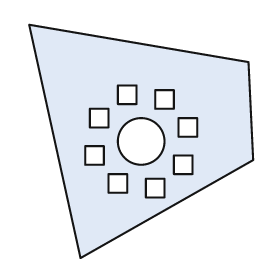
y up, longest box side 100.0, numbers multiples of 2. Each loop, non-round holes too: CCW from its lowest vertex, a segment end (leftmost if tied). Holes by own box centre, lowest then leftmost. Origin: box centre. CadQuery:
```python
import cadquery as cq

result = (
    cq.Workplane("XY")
    .moveTo(-26.0, -50.0)
    .lineTo(48.0, -8.0)
    .lineTo(46.0, 34.0)
    .lineTo(-48.0, 50.0)
    .close()
    .moveTo(2.0, -24.0)
    .lineTo(10.0, -24.0)
    .lineTo(10.0, -16.0)
    .lineTo(2.0, -16.0)
    .close()
    .moveTo(-14.0, -22.0)
    .lineTo(-6.0, -22.0)
    .lineTo(-6.0, -14.0)
    .lineTo(-14.0, -14.0)
    .close()
    .moveTo(14.0, -14.0)
    .lineTo(22.0, -14.0)
    .lineTo(22.0, -6.0)
    .lineTo(14.0, -6.0)
    .close()
    .moveTo(-24.0, -10.0)
    .lineTo(-16.0, -10.0)
    .lineTo(-16.0, -2.0)
    .lineTo(-24.0, -2.0)
    .close()
    .moveTo(0.0, 0.0)
    .circle(10.0)
    .moveTo(16.0, 2.0)
    .lineTo(24.0, 2.0)
    .lineTo(24.0, 10.0)
    .lineTo(16.0, 10.0)
    .close()
    .moveTo(-22.0, 6.0)
    .lineTo(-14.0, 6.0)
    .lineTo(-14.0, 14.0)
    .lineTo(-22.0, 14.0)
    .close()
    .moveTo(6.0, 14.0)
    .lineTo(14.0, 14.0)
    .lineTo(14.0, 22.0)
    .lineTo(6.0, 22.0)
    .close()
    .moveTo(-10.0, 16.0)
    .lineTo(-2.0, 16.0)
    .lineTo(-2.0, 24.0)
    .lineTo(-10.0, 24.0)
    .close()
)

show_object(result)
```